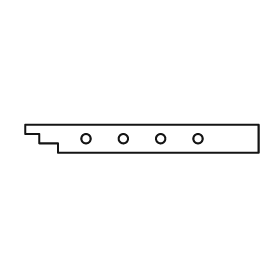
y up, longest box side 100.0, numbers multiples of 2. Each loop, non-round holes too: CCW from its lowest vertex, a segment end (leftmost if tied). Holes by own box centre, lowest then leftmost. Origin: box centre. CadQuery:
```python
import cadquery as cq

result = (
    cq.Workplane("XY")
    .moveTo(-36.0, -6.0)
    .lineTo(50.0, -6.0)
    .lineTo(50.0, 6.0)
    .lineTo(-50.0, 6.0)
    .lineTo(-50.0, 2.0)
    .lineTo(-44.0, 2.0)
    .lineTo(-44.0, -2.0)
    .lineTo(-36.0, -2.0)
    .close()
    .moveTo(-24.0, 0.0)
    .circle(2.0)
    .moveTo(-8.0, 0.0)
    .circle(2.0)
    .moveTo(8.0, 0.0)
    .circle(2.0)
    .moveTo(24.0, 0.0)
    .circle(2.0)
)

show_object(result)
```